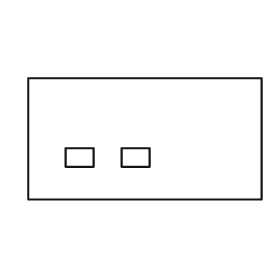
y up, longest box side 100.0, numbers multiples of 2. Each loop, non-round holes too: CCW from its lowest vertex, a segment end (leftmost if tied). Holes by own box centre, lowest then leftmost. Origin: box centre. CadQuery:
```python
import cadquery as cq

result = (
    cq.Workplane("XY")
    .moveTo(-50.0, -26.0)
    .lineTo(50.0, -26.0)
    .lineTo(50.0, 26.0)
    .lineTo(-50.0, 26.0)
    .close()
    .moveTo(-34.0, -12.0)
    .lineTo(-22.0, -12.0)
    .lineTo(-22.0, -4.0)
    .lineTo(-34.0, -4.0)
    .close()
    .moveTo(-10.0, -12.0)
    .lineTo(2.0, -12.0)
    .lineTo(2.0, -4.0)
    .lineTo(-10.0, -4.0)
    .close()
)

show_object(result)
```